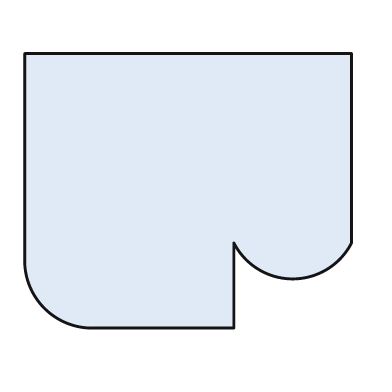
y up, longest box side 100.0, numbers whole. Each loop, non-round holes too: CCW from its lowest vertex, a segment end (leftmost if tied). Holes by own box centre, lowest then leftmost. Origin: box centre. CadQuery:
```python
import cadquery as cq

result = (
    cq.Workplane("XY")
    .moveTo(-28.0, -42.0)
    .lineTo(14.0, -42.0)
    .lineTo(14.0, -16.0)
    .threePointArc((32.0, -27.0), (50.0, -16.0))
    .lineTo(50.0, 42.0)
    .lineTo(-50.0, 42.0)
    .lineTo(-50.0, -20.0)
    .threePointArc((-44.0, -36.0), (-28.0, -42.0))
    .close()
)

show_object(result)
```